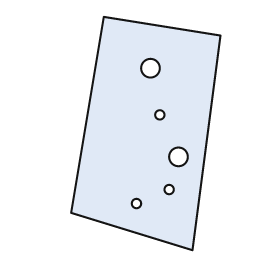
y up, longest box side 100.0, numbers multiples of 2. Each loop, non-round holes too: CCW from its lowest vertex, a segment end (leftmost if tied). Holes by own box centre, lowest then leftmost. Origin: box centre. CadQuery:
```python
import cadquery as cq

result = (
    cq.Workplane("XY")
    .moveTo(20.0, -50.0)
    .lineTo(32.0, 42.0)
    .lineTo(-18.0, 50.0)
    .lineTo(-32.0, -34.0)
    .close()
    .moveTo(-4.0, -30.0)
    .circle(2.0)
    .moveTo(10.0, -24.0)
    .circle(2.0)
    .moveTo(14.0, -10.0)
    .circle(4.0)
    .moveTo(6.0, 8.0)
    .circle(2.0)
    .moveTo(2.0, 28.0)
    .circle(4.0)
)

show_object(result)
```